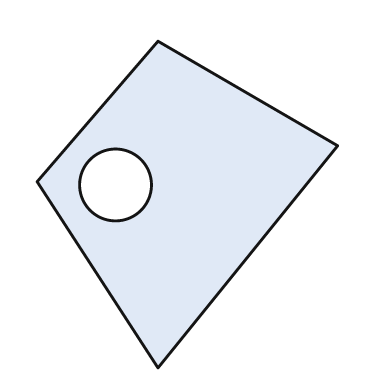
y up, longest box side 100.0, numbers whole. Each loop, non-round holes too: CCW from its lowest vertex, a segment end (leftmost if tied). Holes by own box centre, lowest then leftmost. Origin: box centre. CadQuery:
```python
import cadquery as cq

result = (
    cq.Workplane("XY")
    .moveTo(-9.0, -50.0)
    .lineTo(46.0, 18.0)
    .lineTo(-9.0, 50.0)
    .lineTo(-46.0, 7.0)
    .close()
    .moveTo(-22.0, 6.0)
    .circle(11.0)
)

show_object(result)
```